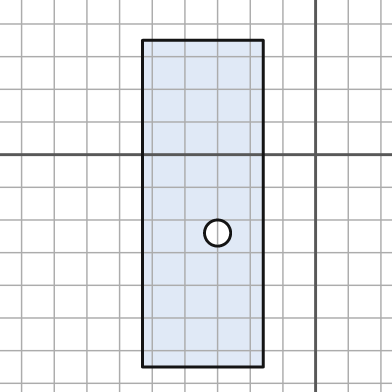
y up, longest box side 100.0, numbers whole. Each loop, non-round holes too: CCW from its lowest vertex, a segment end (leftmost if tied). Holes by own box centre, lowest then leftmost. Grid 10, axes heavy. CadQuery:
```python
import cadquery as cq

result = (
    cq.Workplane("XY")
    .moveTo(-53.0, -65.0)
    .lineTo(-16.0, -65.0)
    .lineTo(-16.0, 35.0)
    .lineTo(-53.0, 35.0)
    .close()
    .moveTo(-30.0, -24.0)
    .circle(4.0)
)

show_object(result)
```